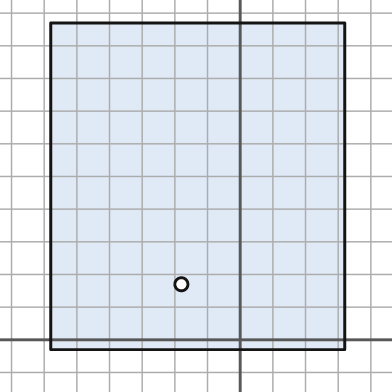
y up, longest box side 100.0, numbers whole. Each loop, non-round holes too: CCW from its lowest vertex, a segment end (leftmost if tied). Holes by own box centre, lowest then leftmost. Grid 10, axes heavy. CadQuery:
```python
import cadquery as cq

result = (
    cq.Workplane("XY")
    .moveTo(-58.0, -3.0)
    .lineTo(32.0, -3.0)
    .lineTo(32.0, 97.0)
    .lineTo(-58.0, 97.0)
    .close()
    .moveTo(-18.0, 17.0)
    .circle(2.0)
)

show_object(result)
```